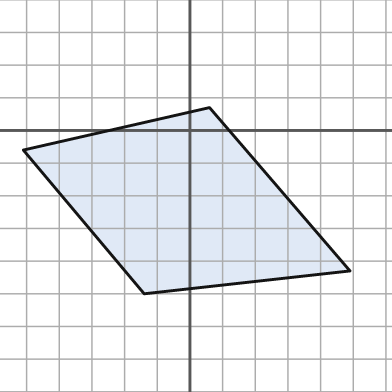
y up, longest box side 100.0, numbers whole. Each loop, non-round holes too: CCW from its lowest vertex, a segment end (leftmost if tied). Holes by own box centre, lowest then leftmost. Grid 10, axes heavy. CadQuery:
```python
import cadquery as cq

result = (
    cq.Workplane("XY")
    .moveTo(-14.0, -50.0)
    .lineTo(49.0, -43.0)
    .lineTo(6.0, 7.0)
    .lineTo(-51.0, -6.0)
    .close()
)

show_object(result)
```